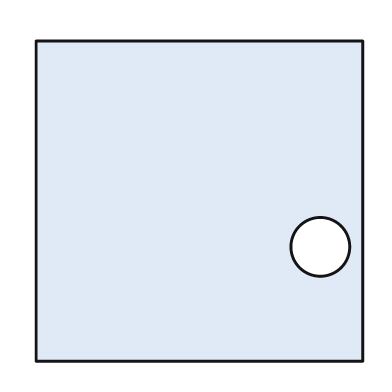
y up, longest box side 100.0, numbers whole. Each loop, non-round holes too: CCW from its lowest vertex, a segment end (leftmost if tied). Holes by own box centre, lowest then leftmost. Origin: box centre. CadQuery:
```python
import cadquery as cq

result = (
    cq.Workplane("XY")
    .moveTo(-50.0, -49.0)
    .lineTo(50.0, -49.0)
    .lineTo(50.0, 49.0)
    .lineTo(-50.0, 49.0)
    .close()
    .moveTo(37.0, -14.0)
    .circle(9.0)
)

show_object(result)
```